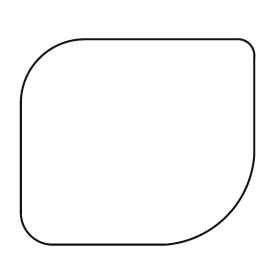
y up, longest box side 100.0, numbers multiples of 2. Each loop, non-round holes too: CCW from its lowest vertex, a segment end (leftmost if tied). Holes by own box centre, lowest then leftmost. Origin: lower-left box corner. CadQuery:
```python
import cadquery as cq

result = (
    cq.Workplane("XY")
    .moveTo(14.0, 0.0)
    .lineTo(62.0, 0.0)
    .threePointArc((88.0, 12.0), (100.0, 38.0))
    .lineTo(100.0, 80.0)
    .threePointArc((98.0, 86.0), (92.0, 88.0))
    .lineTo(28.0, 88.0)
    .threePointArc((8.0, 80.0), (0.0, 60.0))
    .lineTo(0.0, 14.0)
    .threePointArc((4.0, 4.0), (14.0, 0.0))
    .close()
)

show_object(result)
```